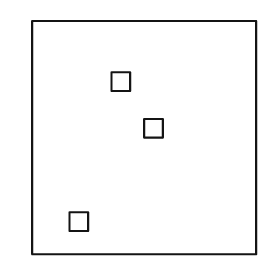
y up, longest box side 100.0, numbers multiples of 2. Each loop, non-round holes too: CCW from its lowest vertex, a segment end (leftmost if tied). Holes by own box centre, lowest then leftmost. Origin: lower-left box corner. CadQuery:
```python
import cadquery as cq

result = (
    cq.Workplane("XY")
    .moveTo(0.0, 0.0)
    .lineTo(96.0, 0.0)
    .lineTo(96.0, 100.0)
    .lineTo(0.0, 100.0)
    .close()
    .moveTo(16.0, 10.0)
    .lineTo(24.0, 10.0)
    .lineTo(24.0, 18.0)
    .lineTo(16.0, 18.0)
    .close()
    .moveTo(48.0, 50.0)
    .lineTo(56.0, 50.0)
    .lineTo(56.0, 58.0)
    .lineTo(48.0, 58.0)
    .close()
    .moveTo(34.0, 70.0)
    .lineTo(42.0, 70.0)
    .lineTo(42.0, 78.0)
    .lineTo(34.0, 78.0)
    .close()
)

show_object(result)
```